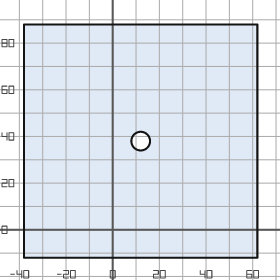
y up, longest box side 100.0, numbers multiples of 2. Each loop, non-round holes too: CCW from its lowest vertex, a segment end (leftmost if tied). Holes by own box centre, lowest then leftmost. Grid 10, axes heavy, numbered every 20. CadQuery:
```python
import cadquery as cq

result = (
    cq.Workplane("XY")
    .moveTo(-38.0, -12.0)
    .lineTo(62.0, -12.0)
    .lineTo(62.0, 88.0)
    .lineTo(-38.0, 88.0)
    .close()
    .moveTo(12.0, 38.0)
    .circle(4.0)
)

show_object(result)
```